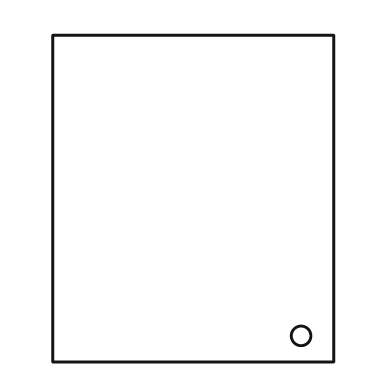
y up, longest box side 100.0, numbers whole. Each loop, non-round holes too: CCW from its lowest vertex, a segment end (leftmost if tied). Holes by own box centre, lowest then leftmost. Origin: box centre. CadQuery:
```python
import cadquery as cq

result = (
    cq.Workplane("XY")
    .moveTo(-43.0, -50.0)
    .lineTo(43.0, -50.0)
    .lineTo(43.0, 50.0)
    .lineTo(-43.0, 50.0)
    .close()
    .moveTo(33.0, -42.0)
    .circle(3.0)
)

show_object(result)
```